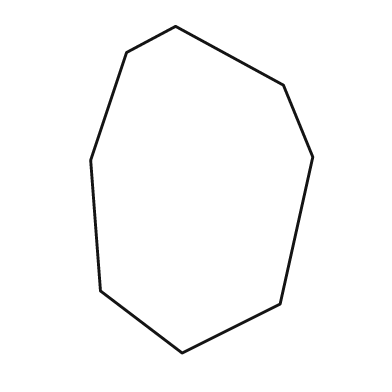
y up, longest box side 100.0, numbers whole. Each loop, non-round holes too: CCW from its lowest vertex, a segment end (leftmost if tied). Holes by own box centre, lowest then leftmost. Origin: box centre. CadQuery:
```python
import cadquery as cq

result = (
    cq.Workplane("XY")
    .moveTo(-6.0, -50.0)
    .lineTo(24.0, -35.0)
    .lineTo(34.0, 10.0)
    .lineTo(25.0, 32.0)
    .lineTo(-8.0, 50.0)
    .lineTo(-23.0, 42.0)
    .lineTo(-34.0, 9.0)
    .lineTo(-31.0, -31.0)
    .close()
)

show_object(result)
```